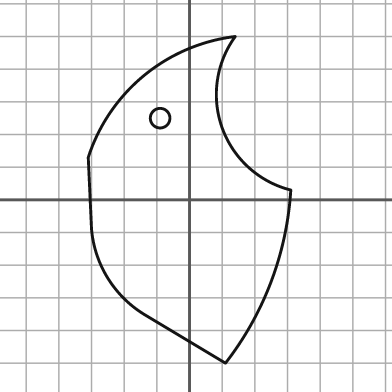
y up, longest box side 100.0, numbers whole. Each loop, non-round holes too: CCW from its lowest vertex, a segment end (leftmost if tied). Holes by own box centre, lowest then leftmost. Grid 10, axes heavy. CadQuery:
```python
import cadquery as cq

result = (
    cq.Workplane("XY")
    .moveTo(11.0, -50.0)
    .threePointArc((25.0, -25.0), (31.0, 3.0))
    .threePointArc((10.0, 22.0), (14.0, 50.0))
    .threePointArc((-14.0, 38.0), (-31.0, 13.0))
    .lineTo(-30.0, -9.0)
    .threePointArc((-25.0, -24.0), (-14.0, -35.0))
    .close()
    .moveTo(-9.0, 25.0)
    .circle(3.0)
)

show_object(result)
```